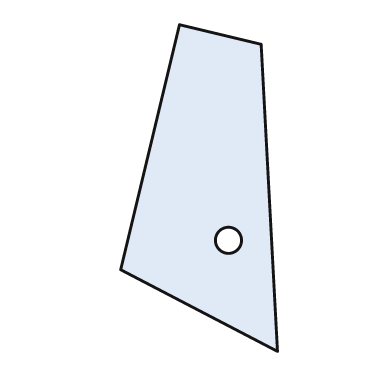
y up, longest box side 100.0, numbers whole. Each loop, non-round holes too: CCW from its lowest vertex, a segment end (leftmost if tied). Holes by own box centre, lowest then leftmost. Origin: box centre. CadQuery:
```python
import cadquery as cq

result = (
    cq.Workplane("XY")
    .moveTo(24.0, -50.0)
    .lineTo(19.0, 44.0)
    .lineTo(-6.0, 50.0)
    .lineTo(-24.0, -25.0)
    .close()
    .moveTo(9.0, -16.0)
    .circle(4.0)
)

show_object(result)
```